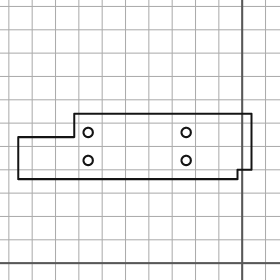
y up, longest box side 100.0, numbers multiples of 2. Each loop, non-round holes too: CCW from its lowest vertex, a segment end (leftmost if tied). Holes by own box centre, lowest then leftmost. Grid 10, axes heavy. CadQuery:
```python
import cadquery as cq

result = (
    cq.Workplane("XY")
    .moveTo(-96.0, 36.0)
    .lineTo(-2.0, 36.0)
    .lineTo(-2.0, 40.0)
    .lineTo(4.0, 40.0)
    .lineTo(4.0, 64.0)
    .lineTo(-72.0, 64.0)
    .lineTo(-72.0, 54.0)
    .lineTo(-96.0, 54.0)
    .close()
    .moveTo(-66.0, 44.0)
    .circle(2.0)
    .moveTo(-24.0, 44.0)
    .circle(2.0)
    .moveTo(-66.0, 56.0)
    .circle(2.0)
    .moveTo(-24.0, 56.0)
    .circle(2.0)
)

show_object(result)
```